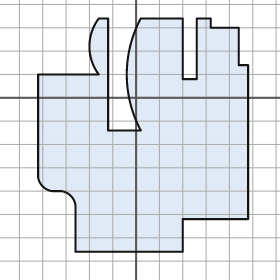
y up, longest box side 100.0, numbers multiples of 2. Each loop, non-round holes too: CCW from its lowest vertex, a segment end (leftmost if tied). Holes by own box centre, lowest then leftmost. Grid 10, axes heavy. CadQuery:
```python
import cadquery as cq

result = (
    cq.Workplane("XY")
    .moveTo(-26.0, -66.0)
    .lineTo(20.0, -66.0)
    .lineTo(20.0, -52.0)
    .lineTo(48.0, -52.0)
    .lineTo(48.0, 14.0)
    .lineTo(44.0, 14.0)
    .lineTo(44.0, 30.0)
    .lineTo(32.0, 30.0)
    .lineTo(32.0, 34.0)
    .lineTo(26.0, 34.0)
    .lineTo(26.0, 8.0)
    .lineTo(20.0, 8.0)
    .lineTo(20.0, 34.0)
    .lineTo(2.0, 34.0)
    .threePointArc((-4.0, 10.0), (2.0, -14.0))
    .lineTo(-12.0, -14.0)
    .lineTo(-12.0, 34.0)
    .lineTo(-16.0, 34.0)
    .threePointArc((-20.0, 22.0), (-16.0, 10.0))
    .lineTo(-42.0, 10.0)
    .lineTo(-42.0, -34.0)
    .threePointArc((-40.0, -38.0), (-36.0, -40.0))
    .lineTo(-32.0, -40.0)
    .threePointArc((-28.0, -42.0), (-26.0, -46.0))
    .close()
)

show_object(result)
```